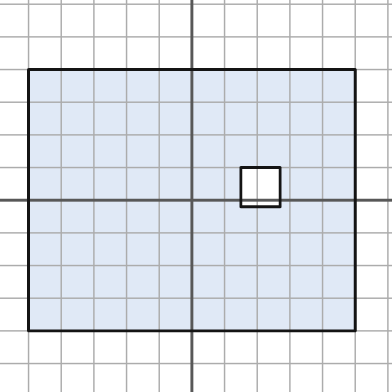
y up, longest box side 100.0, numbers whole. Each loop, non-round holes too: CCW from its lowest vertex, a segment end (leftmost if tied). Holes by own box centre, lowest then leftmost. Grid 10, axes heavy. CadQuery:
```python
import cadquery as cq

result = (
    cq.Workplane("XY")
    .moveTo(-50.0, -40.0)
    .lineTo(50.0, -40.0)
    .lineTo(50.0, 40.0)
    .lineTo(-50.0, 40.0)
    .close()
    .moveTo(15.0, -2.0)
    .lineTo(27.0, -2.0)
    .lineTo(27.0, 10.0)
    .lineTo(15.0, 10.0)
    .close()
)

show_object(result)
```